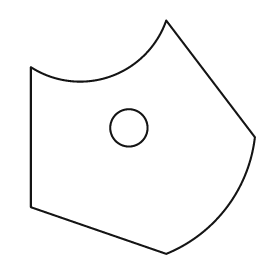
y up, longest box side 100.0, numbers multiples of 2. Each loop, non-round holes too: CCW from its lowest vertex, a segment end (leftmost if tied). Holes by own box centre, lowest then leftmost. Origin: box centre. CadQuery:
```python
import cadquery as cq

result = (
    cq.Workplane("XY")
    .moveTo(10.0, -50.0)
    .threePointArc((36.0, -30.0), (48.0, 0.0))
    .lineTo(10.0, 50.0)
    .threePointArc((-14.0, 26.0), (-48.0, 30.0))
    .lineTo(-48.0, -30.0)
    .close()
    .moveTo(-6.0, 4.0)
    .circle(8.0)
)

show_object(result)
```